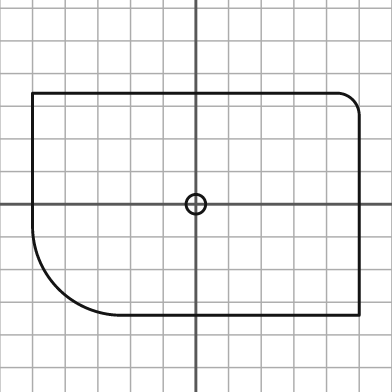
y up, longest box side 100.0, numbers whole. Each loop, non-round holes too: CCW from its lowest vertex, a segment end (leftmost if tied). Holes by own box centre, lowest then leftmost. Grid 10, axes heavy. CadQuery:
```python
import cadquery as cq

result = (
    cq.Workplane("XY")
    .moveTo(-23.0, -34.0)
    .lineTo(50.0, -34.0)
    .lineTo(50.0, 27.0)
    .threePointArc((48.0, 32.0), (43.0, 34.0))
    .lineTo(-50.0, 34.0)
    .lineTo(-50.0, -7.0)
    .threePointArc((-42.0, -26.0), (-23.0, -34.0))
    .close()
    .moveTo(0.0, 0.0)
    .circle(3.0)
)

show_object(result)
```